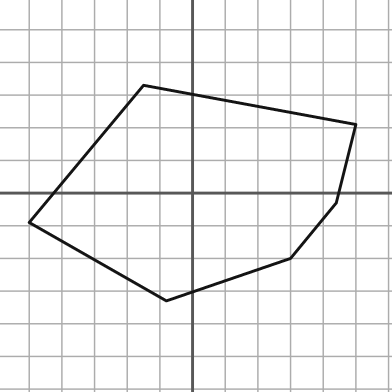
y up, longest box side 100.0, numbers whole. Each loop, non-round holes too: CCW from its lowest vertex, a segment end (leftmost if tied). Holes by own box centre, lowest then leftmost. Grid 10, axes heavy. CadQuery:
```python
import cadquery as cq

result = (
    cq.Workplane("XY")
    .moveTo(-8.0, -33.0)
    .lineTo(30.0, -20.0)
    .lineTo(44.0, -3.0)
    .lineTo(50.0, 21.0)
    .lineTo(-15.0, 33.0)
    .lineTo(-50.0, -9.0)
    .close()
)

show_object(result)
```